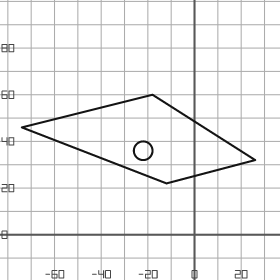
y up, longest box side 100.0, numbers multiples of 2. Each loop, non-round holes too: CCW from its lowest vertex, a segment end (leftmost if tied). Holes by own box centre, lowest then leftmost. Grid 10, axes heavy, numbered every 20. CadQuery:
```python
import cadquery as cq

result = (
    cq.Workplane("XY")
    .moveTo(-12.0, 22.0)
    .lineTo(26.0, 32.0)
    .lineTo(-18.0, 60.0)
    .lineTo(-74.0, 46.0)
    .close()
    .moveTo(-22.0, 36.0)
    .circle(4.0)
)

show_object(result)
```